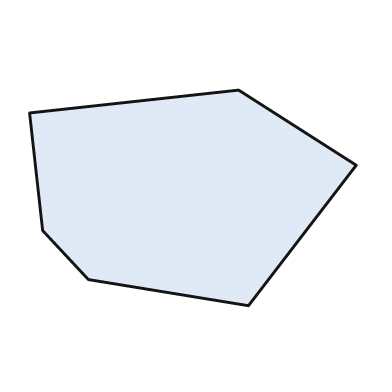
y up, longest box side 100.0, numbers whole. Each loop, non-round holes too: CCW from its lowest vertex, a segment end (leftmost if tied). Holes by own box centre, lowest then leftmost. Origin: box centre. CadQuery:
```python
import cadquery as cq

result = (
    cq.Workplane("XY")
    .moveTo(17.0, -33.0)
    .lineTo(50.0, 10.0)
    .lineTo(14.0, 33.0)
    .lineTo(-50.0, 26.0)
    .lineTo(-46.0, -10.0)
    .lineTo(-32.0, -25.0)
    .close()
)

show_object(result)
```